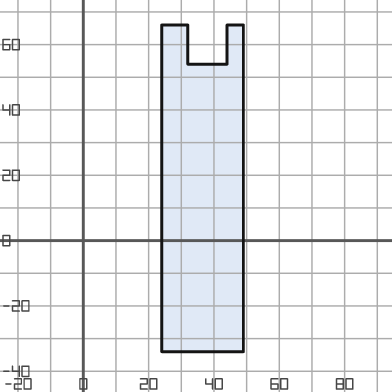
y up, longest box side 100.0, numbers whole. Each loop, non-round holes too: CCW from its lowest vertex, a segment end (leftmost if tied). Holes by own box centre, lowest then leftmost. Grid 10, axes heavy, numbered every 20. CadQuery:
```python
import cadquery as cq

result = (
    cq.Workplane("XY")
    .moveTo(24.0, -34.0)
    .lineTo(49.0, -34.0)
    .lineTo(49.0, 66.0)
    .lineTo(44.0, 66.0)
    .lineTo(44.0, 54.0)
    .lineTo(32.0, 54.0)
    .lineTo(32.0, 66.0)
    .lineTo(24.0, 66.0)
    .close()
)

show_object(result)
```